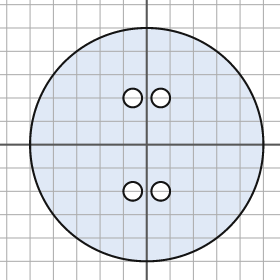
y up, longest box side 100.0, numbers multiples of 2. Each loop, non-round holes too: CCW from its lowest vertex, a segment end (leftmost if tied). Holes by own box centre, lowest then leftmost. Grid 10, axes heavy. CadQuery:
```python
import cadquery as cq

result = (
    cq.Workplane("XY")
    .moveTo(0.0, 0.0)
    .circle(50.0)
    .moveTo(-6.0, -20.0)
    .circle(4.0)
    .moveTo(6.0, -20.0)
    .circle(4.0)
    .moveTo(-6.0, 20.0)
    .circle(4.0)
    .moveTo(6.0, 20.0)
    .circle(4.0)
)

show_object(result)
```